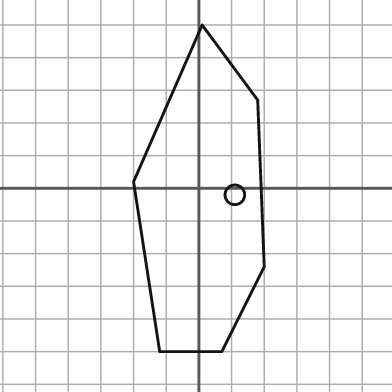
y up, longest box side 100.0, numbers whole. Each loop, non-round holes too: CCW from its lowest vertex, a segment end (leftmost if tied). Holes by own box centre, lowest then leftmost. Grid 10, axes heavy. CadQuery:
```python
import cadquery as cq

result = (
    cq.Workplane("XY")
    .moveTo(-12.0, -50.0)
    .lineTo(7.0, -50.0)
    .lineTo(20.0, -24.0)
    .lineTo(18.0, 27.0)
    .lineTo(1.0, 50.0)
    .lineTo(-20.0, 2.0)
    .close()
    .moveTo(11.0, -2.0)
    .circle(3.0)
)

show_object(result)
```